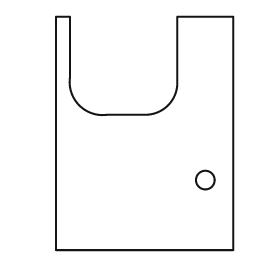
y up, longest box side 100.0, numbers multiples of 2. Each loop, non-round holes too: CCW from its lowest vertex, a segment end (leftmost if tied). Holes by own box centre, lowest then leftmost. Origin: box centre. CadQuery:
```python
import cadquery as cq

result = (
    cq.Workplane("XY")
    .moveTo(-38.0, -50.0)
    .lineTo(38.0, -50.0)
    .lineTo(38.0, 50.0)
    .lineTo(14.0, 50.0)
    .lineTo(14.0, 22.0)
    .threePointArc((10.0, 12.0), (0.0, 8.0))
    .lineTo(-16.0, 8.0)
    .threePointArc((-28.0, 12.0), (-32.0, 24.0))
    .lineTo(-32.0, 50.0)
    .lineTo(-38.0, 50.0)
    .close()
    .moveTo(26.0, -20.0)
    .circle(4.0)
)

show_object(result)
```